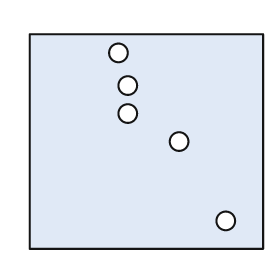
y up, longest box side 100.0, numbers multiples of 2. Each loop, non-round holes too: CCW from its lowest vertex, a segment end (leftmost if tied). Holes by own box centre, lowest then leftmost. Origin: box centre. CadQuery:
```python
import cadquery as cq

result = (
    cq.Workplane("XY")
    .moveTo(-50.0, -46.0)
    .lineTo(50.0, -46.0)
    .lineTo(50.0, 46.0)
    .lineTo(-50.0, 46.0)
    .close()
    .moveTo(34.0, -34.0)
    .circle(4.0)
    .moveTo(14.0, 0.0)
    .circle(4.0)
    .moveTo(-8.0, 12.0)
    .circle(4.0)
    .moveTo(-8.0, 24.0)
    .circle(4.0)
    .moveTo(-12.0, 38.0)
    .circle(4.0)
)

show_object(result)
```